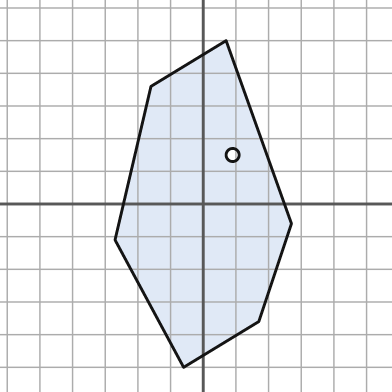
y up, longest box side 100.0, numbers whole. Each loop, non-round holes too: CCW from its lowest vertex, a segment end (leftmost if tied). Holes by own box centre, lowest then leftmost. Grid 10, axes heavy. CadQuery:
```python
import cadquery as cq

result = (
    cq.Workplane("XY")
    .moveTo(-6.0, -50.0)
    .lineTo(17.0, -36.0)
    .lineTo(27.0, -6.0)
    .lineTo(7.0, 50.0)
    .lineTo(-16.0, 36.0)
    .lineTo(-27.0, -11.0)
    .close()
    .moveTo(9.0, 15.0)
    .circle(2.0)
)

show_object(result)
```